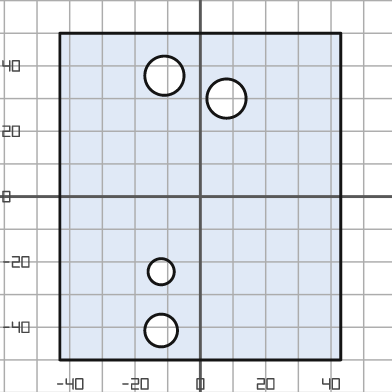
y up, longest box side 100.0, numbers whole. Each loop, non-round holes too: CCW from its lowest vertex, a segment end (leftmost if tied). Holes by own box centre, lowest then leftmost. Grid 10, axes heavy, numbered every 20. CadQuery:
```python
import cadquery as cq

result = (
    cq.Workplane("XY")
    .moveTo(-43.0, -50.0)
    .lineTo(43.0, -50.0)
    .lineTo(43.0, 50.0)
    .lineTo(-43.0, 50.0)
    .close()
    .moveTo(-12.0, -41.0)
    .circle(5.0)
    .moveTo(-12.0, -23.0)
    .circle(4.0)
    .moveTo(8.0, 30.0)
    .circle(6.0)
    .moveTo(-11.0, 37.0)
    .circle(6.0)
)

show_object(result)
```